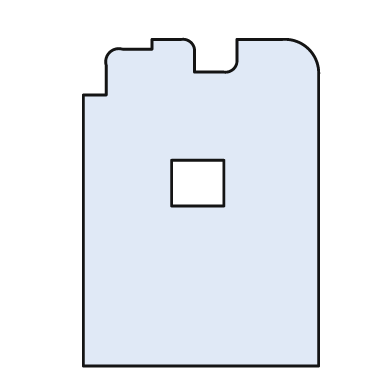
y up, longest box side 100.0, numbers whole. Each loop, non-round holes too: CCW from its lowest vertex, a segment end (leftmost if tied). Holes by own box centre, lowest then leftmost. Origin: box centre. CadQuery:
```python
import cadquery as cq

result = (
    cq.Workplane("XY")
    .moveTo(-36.0, -50.0)
    .lineTo(36.0, -50.0)
    .lineTo(36.0, 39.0)
    .threePointArc((33.0, 47.0), (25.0, 50.0))
    .lineTo(11.0, 50.0)
    .lineTo(11.0, 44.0)
    .threePointArc((10.0, 41.0), (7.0, 40.0))
    .lineTo(-2.0, 40.0)
    .lineTo(-2.0, 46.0)
    .threePointArc((-3.0, 49.0), (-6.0, 50.0))
    .lineTo(-15.0, 50.0)
    .lineTo(-15.0, 47.0)
    .lineTo(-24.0, 47.0)
    .threePointArc((-28.0, 46.0), (-29.0, 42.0))
    .lineTo(-29.0, 33.0)
    .lineTo(-36.0, 33.0)
    .close()
    .moveTo(-9.0, -1.0)
    .lineTo(7.0, -1.0)
    .lineTo(7.0, 13.0)
    .lineTo(-9.0, 13.0)
    .close()
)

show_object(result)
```